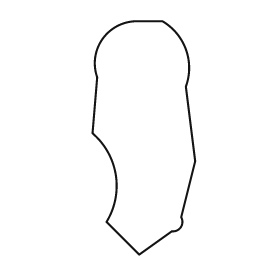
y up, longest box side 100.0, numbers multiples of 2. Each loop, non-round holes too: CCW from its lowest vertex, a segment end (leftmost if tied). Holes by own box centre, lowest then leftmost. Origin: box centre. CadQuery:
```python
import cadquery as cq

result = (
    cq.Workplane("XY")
    .moveTo(-2.0, -50.0)
    .lineTo(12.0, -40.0)
    .threePointArc((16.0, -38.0), (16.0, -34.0))
    .lineTo(22.0, -10.0)
    .lineTo(18.0, 22.0)
    .threePointArc((18.0, 38.0), (8.0, 50.0))
    .lineTo(-4.0, 50.0)
    .threePointArc((-18.0, 42.0), (-20.0, 26.0))
    .lineTo(-22.0, 2.0)
    .threePointArc((-12.0, -16.0), (-16.0, -36.0))
    .close()
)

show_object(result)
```